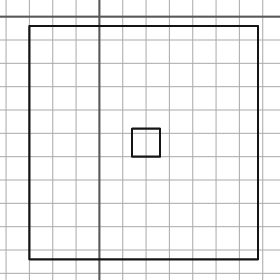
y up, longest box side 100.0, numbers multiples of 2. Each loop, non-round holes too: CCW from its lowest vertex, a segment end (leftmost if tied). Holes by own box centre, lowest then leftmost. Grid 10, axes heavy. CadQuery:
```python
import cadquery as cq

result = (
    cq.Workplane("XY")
    .moveTo(-30.0, -104.0)
    .lineTo(68.0, -104.0)
    .lineTo(68.0, -4.0)
    .lineTo(-30.0, -4.0)
    .close()
    .moveTo(14.0, -60.0)
    .lineTo(26.0, -60.0)
    .lineTo(26.0, -48.0)
    .lineTo(14.0, -48.0)
    .close()
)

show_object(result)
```